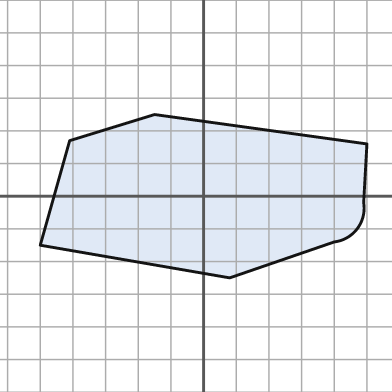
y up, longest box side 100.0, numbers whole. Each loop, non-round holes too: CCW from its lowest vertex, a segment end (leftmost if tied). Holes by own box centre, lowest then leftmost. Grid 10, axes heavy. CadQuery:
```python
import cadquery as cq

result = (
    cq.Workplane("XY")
    .moveTo(8.0, -25.0)
    .lineTo(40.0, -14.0)
    .threePointArc((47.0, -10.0), (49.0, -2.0))
    .lineTo(50.0, 16.0)
    .lineTo(-15.0, 25.0)
    .lineTo(-41.0, 17.0)
    .lineTo(-50.0, -15.0)
    .close()
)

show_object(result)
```